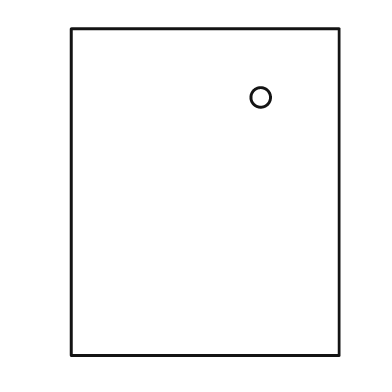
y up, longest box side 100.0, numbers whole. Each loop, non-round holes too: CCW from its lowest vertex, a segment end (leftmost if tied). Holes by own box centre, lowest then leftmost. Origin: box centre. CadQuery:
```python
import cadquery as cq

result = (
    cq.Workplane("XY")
    .moveTo(-41.0, -50.0)
    .lineTo(41.0, -50.0)
    .lineTo(41.0, 50.0)
    .lineTo(-41.0, 50.0)
    .close()
    .moveTo(17.0, 29.0)
    .circle(3.0)
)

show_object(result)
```